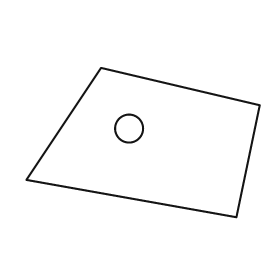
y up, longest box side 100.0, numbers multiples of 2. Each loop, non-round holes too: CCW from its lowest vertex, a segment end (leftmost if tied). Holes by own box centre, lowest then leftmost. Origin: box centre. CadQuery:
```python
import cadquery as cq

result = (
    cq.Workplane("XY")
    .moveTo(40.0, -32.0)
    .lineTo(50.0, 16.0)
    .lineTo(-18.0, 32.0)
    .lineTo(-50.0, -16.0)
    .close()
    .moveTo(-6.0, 6.0)
    .circle(6.0)
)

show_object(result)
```